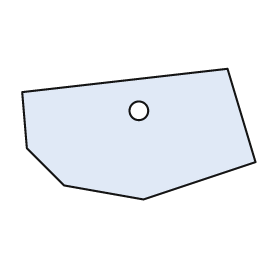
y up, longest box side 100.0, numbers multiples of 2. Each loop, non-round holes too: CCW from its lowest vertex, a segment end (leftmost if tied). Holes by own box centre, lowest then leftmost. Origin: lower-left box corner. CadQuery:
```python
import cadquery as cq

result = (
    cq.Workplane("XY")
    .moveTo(52.0, 0.0)
    .lineTo(100.0, 16.0)
    .lineTo(88.0, 56.0)
    .lineTo(0.0, 46.0)
    .lineTo(2.0, 22.0)
    .lineTo(18.0, 6.0)
    .close()
    .moveTo(50.0, 38.0)
    .circle(4.0)
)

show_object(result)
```